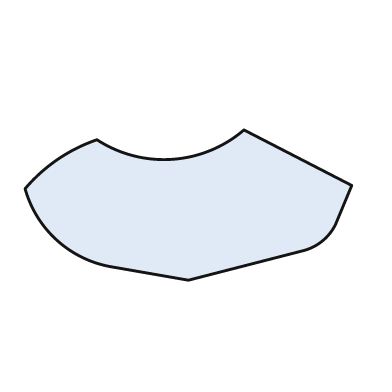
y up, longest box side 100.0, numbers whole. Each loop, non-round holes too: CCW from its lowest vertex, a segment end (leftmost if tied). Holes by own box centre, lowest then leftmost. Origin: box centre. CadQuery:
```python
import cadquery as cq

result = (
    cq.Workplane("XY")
    .moveTo(0.0, -23.0)
    .lineTo(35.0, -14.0)
    .threePointArc((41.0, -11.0), (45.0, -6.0))
    .lineTo(50.0, 6.0)
    .lineTo(17.0, 23.0)
    .threePointArc((-5.0, 14.0), (-28.0, 20.0))
    .threePointArc((-40.0, 14.0), (-50.0, 5.0))
    .threePointArc((-40.0, -11.0), (-23.0, -19.0))
    .close()
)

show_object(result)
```